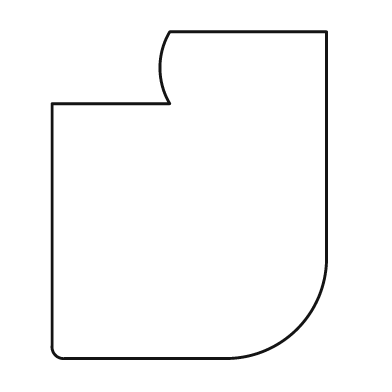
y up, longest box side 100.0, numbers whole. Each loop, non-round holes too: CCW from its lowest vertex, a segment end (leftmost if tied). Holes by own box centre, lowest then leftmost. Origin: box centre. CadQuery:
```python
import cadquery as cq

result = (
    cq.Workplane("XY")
    .moveTo(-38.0, -50.0)
    .lineTo(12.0, -50.0)
    .threePointArc((33.0, -41.0), (42.0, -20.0))
    .lineTo(42.0, 50.0)
    .lineTo(-6.0, 50.0)
    .threePointArc((-9.0, 39.0), (-6.0, 28.0))
    .lineTo(-42.0, 28.0)
    .lineTo(-42.0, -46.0)
    .threePointArc((-41.0, -49.0), (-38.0, -50.0))
    .close()
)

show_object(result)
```